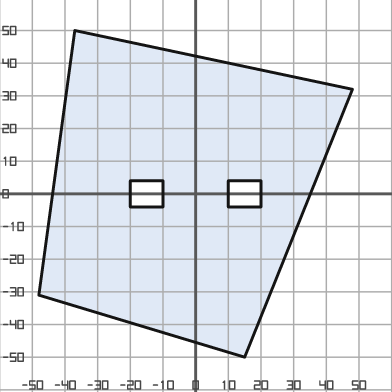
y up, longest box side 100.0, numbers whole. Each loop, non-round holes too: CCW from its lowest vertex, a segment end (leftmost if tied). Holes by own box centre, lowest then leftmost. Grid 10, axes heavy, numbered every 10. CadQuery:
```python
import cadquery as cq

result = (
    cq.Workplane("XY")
    .moveTo(15.0, -50.0)
    .lineTo(48.0, 32.0)
    .lineTo(-37.0, 50.0)
    .lineTo(-48.0, -31.0)
    .close()
    .moveTo(-20.0, -4.0)
    .lineTo(-10.0, -4.0)
    .lineTo(-10.0, 4.0)
    .lineTo(-20.0, 4.0)
    .close()
    .moveTo(10.0, -4.0)
    .lineTo(20.0, -4.0)
    .lineTo(20.0, 4.0)
    .lineTo(10.0, 4.0)
    .close()
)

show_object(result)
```